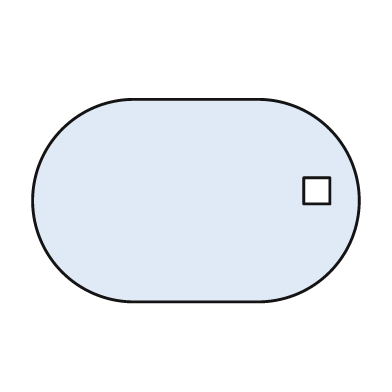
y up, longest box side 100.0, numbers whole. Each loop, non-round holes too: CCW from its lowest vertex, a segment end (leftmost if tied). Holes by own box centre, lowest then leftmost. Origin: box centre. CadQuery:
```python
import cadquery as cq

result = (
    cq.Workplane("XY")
    .moveTo(-19.0, -31.0)
    .lineTo(19.0, -31.0)
    .threePointArc((50.0, 0.0), (19.0, 31.0))
    .lineTo(-19.0, 31.0)
    .threePointArc((-50.0, 0.0), (-19.0, -31.0))
    .close()
    .moveTo(33.0, -1.0)
    .lineTo(41.0, -1.0)
    .lineTo(41.0, 7.0)
    .lineTo(33.0, 7.0)
    .close()
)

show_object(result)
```